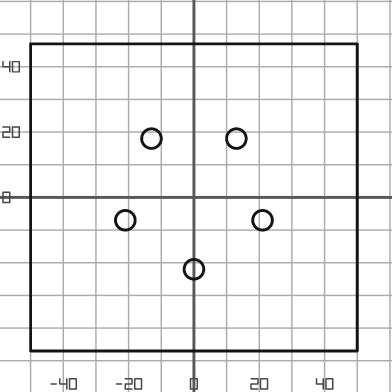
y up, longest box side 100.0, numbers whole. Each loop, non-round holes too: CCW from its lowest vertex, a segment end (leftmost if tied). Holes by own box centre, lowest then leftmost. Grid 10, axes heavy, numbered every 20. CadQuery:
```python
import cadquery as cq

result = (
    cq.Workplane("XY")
    .moveTo(-50.0, -47.0)
    .lineTo(50.0, -47.0)
    .lineTo(50.0, 47.0)
    .lineTo(-50.0, 47.0)
    .close()
    .moveTo(0.0, -22.0)
    .circle(3.0)
    .moveTo(-21.0, -7.0)
    .circle(3.0)
    .moveTo(21.0, -7.0)
    .circle(3.0)
    .moveTo(-13.0, 18.0)
    .circle(3.0)
    .moveTo(13.0, 18.0)
    .circle(3.0)
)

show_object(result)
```